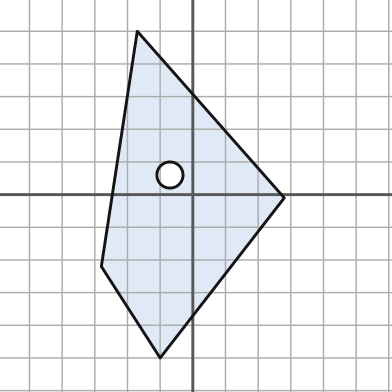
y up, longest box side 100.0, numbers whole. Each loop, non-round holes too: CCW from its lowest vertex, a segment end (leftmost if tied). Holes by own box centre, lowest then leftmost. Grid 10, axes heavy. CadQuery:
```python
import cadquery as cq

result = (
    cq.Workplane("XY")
    .moveTo(-10.0, -50.0)
    .lineTo(28.0, -1.0)
    .lineTo(-17.0, 50.0)
    .lineTo(-28.0, -22.0)
    .close()
    .moveTo(-7.0, 6.0)
    .circle(4.0)
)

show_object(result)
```